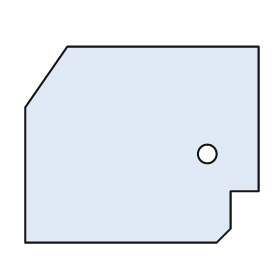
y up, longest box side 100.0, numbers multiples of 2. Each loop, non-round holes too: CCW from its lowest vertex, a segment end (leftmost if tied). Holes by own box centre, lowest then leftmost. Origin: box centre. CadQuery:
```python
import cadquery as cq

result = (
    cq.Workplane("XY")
    .moveTo(-50.0, -42.0)
    .lineTo(32.0, -42.0)
    .lineTo(38.0, -36.0)
    .lineTo(38.0, -20.0)
    .lineTo(50.0, -20.0)
    .lineTo(50.0, 42.0)
    .lineTo(-32.0, 42.0)
    .lineTo(-50.0, 16.0)
    .close()
    .moveTo(28.0, -4.0)
    .circle(4.0)
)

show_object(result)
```